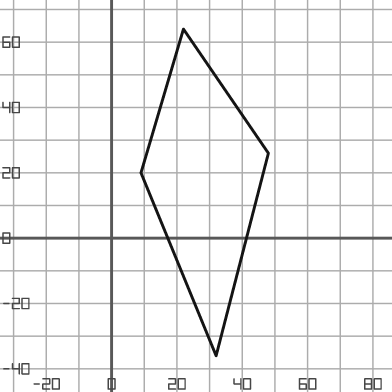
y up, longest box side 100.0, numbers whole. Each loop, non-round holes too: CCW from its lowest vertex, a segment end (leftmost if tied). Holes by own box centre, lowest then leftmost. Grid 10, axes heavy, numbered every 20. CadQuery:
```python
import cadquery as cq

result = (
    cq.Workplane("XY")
    .moveTo(32.0, -36.0)
    .lineTo(48.0, 26.0)
    .lineTo(22.0, 64.0)
    .lineTo(9.0, 20.0)
    .close()
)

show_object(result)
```